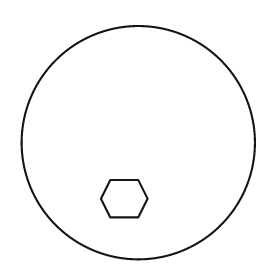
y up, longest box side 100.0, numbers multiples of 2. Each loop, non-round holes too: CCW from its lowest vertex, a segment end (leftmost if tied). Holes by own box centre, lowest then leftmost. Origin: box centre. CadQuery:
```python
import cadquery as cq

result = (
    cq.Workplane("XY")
    .moveTo(0.0, 0.0)
    .circle(50.0)
    .moveTo(-12.0, -32.0)
    .lineTo(0.0, -32.0)
    .lineTo(4.0, -24.0)
    .lineTo(0.0, -16.0)
    .lineTo(-12.0, -16.0)
    .lineTo(-16.0, -24.0)
    .close()
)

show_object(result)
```